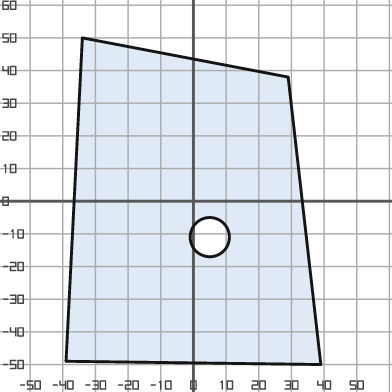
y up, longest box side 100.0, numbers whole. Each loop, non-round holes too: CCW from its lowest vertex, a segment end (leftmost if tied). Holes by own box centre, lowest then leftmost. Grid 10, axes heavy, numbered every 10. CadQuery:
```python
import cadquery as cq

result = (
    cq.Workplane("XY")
    .moveTo(39.0, -50.0)
    .lineTo(29.0, 38.0)
    .lineTo(-34.0, 50.0)
    .lineTo(-39.0, -49.0)
    .close()
    .moveTo(5.0, -11.0)
    .circle(6.0)
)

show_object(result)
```